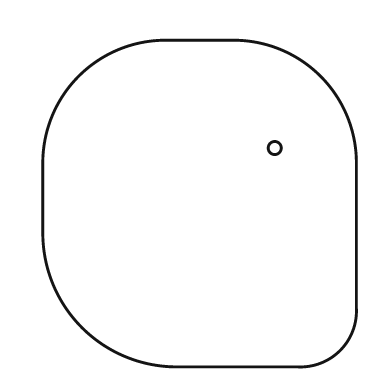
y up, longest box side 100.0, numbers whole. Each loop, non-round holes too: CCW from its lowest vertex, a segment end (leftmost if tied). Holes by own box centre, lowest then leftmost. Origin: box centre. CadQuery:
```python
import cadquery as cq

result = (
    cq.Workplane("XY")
    .moveTo(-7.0, -50.0)
    .lineTo(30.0, -50.0)
    .threePointArc((43.0, -45.0), (48.0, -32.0))
    .lineTo(48.0, 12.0)
    .threePointArc((37.0, 39.0), (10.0, 50.0))
    .lineTo(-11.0, 50.0)
    .threePointArc((-37.0, 39.0), (-48.0, 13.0))
    .lineTo(-48.0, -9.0)
    .threePointArc((-36.0, -38.0), (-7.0, -50.0))
    .close()
    .moveTo(23.0, 17.0)
    .circle(2.0)
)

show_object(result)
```